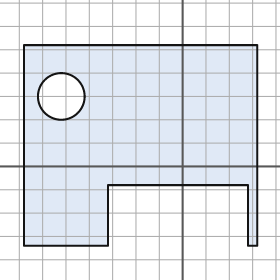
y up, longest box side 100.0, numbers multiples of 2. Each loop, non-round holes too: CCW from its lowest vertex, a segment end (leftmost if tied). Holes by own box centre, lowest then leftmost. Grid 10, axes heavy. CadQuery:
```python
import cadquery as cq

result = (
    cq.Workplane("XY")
    .moveTo(-68.0, -34.0)
    .lineTo(-32.0, -34.0)
    .lineTo(-32.0, -8.0)
    .lineTo(28.0, -8.0)
    .lineTo(28.0, -34.0)
    .lineTo(32.0, -34.0)
    .lineTo(32.0, 52.0)
    .lineTo(-68.0, 52.0)
    .close()
    .moveTo(-52.0, 30.0)
    .circle(10.0)
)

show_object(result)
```